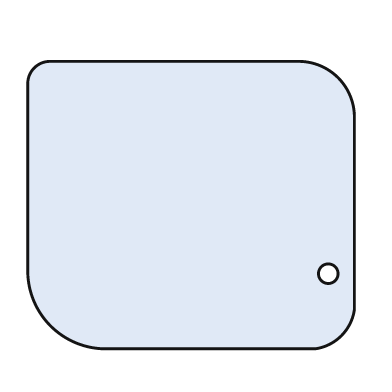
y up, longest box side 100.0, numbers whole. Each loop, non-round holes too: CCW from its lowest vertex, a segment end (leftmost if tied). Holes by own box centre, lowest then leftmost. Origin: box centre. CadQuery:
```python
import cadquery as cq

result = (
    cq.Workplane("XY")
    .moveTo(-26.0, -44.0)
    .lineTo(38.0, -44.0)
    .threePointArc((46.0, -40.0), (50.0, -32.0))
    .lineTo(50.0, 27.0)
    .threePointArc((45.0, 39.0), (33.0, 44.0))
    .lineTo(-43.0, 44.0)
    .threePointArc((-48.0, 42.0), (-50.0, 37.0))
    .lineTo(-50.0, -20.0)
    .threePointArc((-43.0, -37.0), (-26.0, -44.0))
    .close()
    .moveTo(42.0, -21.0)
    .circle(3.0)
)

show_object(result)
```